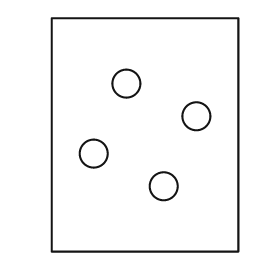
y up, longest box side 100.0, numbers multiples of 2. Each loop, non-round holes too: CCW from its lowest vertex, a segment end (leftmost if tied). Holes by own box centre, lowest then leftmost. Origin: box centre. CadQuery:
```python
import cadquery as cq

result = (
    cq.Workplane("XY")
    .moveTo(-40.0, -50.0)
    .lineTo(40.0, -50.0)
    .lineTo(40.0, 50.0)
    .lineTo(-40.0, 50.0)
    .close()
    .moveTo(8.0, -22.0)
    .circle(6.0)
    .moveTo(-22.0, -8.0)
    .circle(6.0)
    .moveTo(22.0, 8.0)
    .circle(6.0)
    .moveTo(-8.0, 22.0)
    .circle(6.0)
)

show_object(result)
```